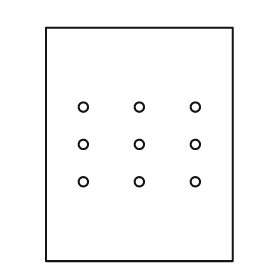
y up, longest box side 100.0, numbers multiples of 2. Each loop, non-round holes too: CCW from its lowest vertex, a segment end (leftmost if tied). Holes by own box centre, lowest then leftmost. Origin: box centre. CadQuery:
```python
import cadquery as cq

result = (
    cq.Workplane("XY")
    .moveTo(-40.0, -50.0)
    .lineTo(40.0, -50.0)
    .lineTo(40.0, 50.0)
    .lineTo(-40.0, 50.0)
    .close()
    .moveTo(-24.0, -16.0)
    .circle(2.0)
    .moveTo(0.0, -16.0)
    .circle(2.0)
    .moveTo(24.0, -16.0)
    .circle(2.0)
    .moveTo(-24.0, 0.0)
    .circle(2.0)
    .moveTo(0.0, 0.0)
    .circle(2.0)
    .moveTo(24.0, 0.0)
    .circle(2.0)
    .moveTo(-24.0, 16.0)
    .circle(2.0)
    .moveTo(0.0, 16.0)
    .circle(2.0)
    .moveTo(24.0, 16.0)
    .circle(2.0)
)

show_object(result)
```